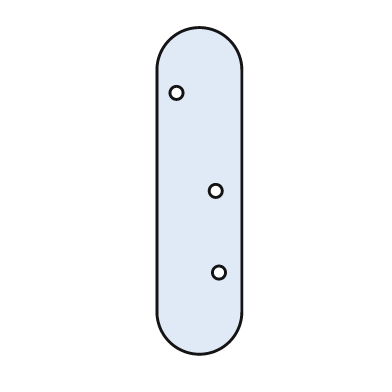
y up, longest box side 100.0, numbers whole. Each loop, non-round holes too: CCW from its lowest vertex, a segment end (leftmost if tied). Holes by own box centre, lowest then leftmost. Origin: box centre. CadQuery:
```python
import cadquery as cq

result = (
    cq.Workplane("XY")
    .moveTo(-13.0, -37.0)
    .threePointArc((0.0, -50.0), (13.0, -37.0))
    .lineTo(13.0, 37.0)
    .threePointArc((0.0, 50.0), (-13.0, 37.0))
    .close()
    .moveTo(6.0, -25.0)
    .circle(2.0)
    .moveTo(5.0, 0.0)
    .circle(2.0)
    .moveTo(-7.0, 30.0)
    .circle(2.0)
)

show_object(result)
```